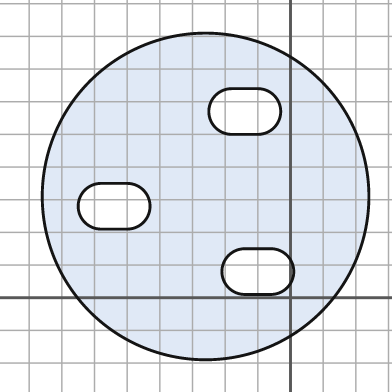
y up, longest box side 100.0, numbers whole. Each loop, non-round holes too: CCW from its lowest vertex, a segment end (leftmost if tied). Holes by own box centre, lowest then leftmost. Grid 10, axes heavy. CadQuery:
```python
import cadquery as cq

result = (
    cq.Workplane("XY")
    .moveTo(-26.0, 31.0)
    .circle(50.0)
    .moveTo(-14.0, 1.0)
    .lineTo(-6.0, 1.0)
    .threePointArc((1.0, 8.0), (-6.0, 15.0))
    .lineTo(-14.0, 15.0)
    .threePointArc((-21.0, 8.0), (-14.0, 1.0))
    .close()
    .moveTo(-58.0, 21.0)
    .lineTo(-50.0, 21.0)
    .threePointArc((-43.0, 28.0), (-50.0, 35.0))
    .lineTo(-58.0, 35.0)
    .threePointArc((-65.0, 28.0), (-58.0, 21.0))
    .close()
    .moveTo(-18.0, 50.0)
    .lineTo(-10.0, 50.0)
    .threePointArc((-3.0, 57.0), (-10.0, 64.0))
    .lineTo(-18.0, 64.0)
    .threePointArc((-25.0, 57.0), (-18.0, 50.0))
    .close()
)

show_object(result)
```